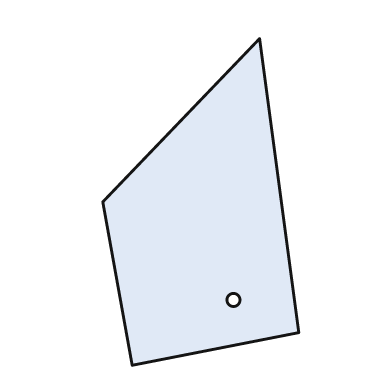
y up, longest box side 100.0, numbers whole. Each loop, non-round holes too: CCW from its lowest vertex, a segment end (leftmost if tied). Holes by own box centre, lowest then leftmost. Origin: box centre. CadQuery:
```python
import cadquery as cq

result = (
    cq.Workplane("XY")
    .moveTo(-21.0, -50.0)
    .lineTo(30.0, -40.0)
    .lineTo(18.0, 50.0)
    .lineTo(-30.0, 0.0)
    .close()
    .moveTo(10.0, -30.0)
    .circle(2.0)
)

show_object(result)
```